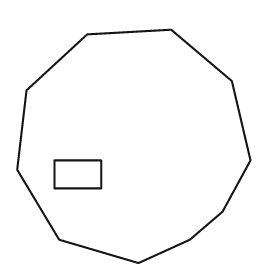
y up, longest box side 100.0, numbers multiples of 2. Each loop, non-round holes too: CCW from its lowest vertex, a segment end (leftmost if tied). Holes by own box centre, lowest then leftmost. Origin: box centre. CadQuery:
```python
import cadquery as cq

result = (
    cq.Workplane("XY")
    .moveTo(2.0, -50.0)
    .lineTo(24.0, -40.0)
    .lineTo(38.0, -28.0)
    .lineTo(50.0, -6.0)
    .lineTo(42.0, 28.0)
    .lineTo(16.0, 50.0)
    .lineTo(-20.0, 48.0)
    .lineTo(-46.0, 24.0)
    .lineTo(-50.0, -10.0)
    .lineTo(-32.0, -40.0)
    .close()
    .moveTo(-34.0, -18.0)
    .lineTo(-14.0, -18.0)
    .lineTo(-14.0, -6.0)
    .lineTo(-34.0, -6.0)
    .close()
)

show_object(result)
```